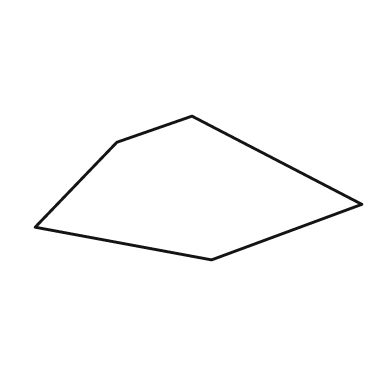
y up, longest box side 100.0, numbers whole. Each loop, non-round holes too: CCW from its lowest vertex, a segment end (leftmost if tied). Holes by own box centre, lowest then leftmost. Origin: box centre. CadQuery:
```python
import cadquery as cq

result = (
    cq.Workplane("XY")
    .moveTo(4.0, -22.0)
    .lineTo(50.0, -5.0)
    .lineTo(-2.0, 22.0)
    .lineTo(-25.0, 14.0)
    .lineTo(-50.0, -12.0)
    .close()
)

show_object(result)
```